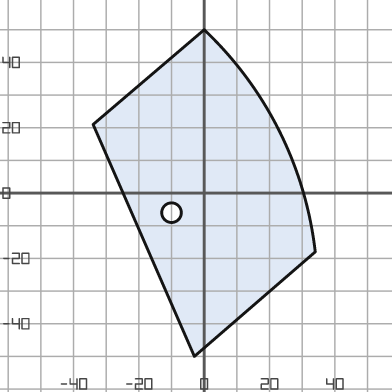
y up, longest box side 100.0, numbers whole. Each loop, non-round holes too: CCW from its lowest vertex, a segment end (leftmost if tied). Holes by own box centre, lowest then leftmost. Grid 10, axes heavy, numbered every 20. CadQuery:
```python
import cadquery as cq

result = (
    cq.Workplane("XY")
    .moveTo(-3.0, -50.0)
    .lineTo(34.0, -18.0)
    .threePointArc((23.0, 19.0), (0.0, 50.0))
    .lineTo(-34.0, 21.0)
    .close()
    .moveTo(-10.0, -6.0)
    .circle(3.0)
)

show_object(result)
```